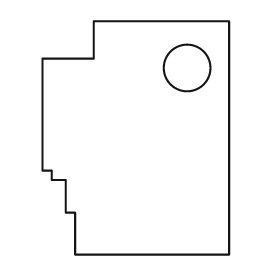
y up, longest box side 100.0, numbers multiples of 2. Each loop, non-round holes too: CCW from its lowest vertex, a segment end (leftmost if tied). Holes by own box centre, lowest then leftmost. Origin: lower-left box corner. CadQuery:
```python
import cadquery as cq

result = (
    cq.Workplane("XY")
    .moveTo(14.0, 0.0)
    .lineTo(80.0, 0.0)
    .lineTo(80.0, 100.0)
    .lineTo(22.0, 100.0)
    .lineTo(22.0, 84.0)
    .lineTo(0.0, 84.0)
    .lineTo(0.0, 36.0)
    .lineTo(4.0, 36.0)
    .lineTo(4.0, 32.0)
    .lineTo(10.0, 32.0)
    .lineTo(10.0, 18.0)
    .lineTo(14.0, 18.0)
    .close()
    .moveTo(62.0, 80.0)
    .circle(10.0)
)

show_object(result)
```